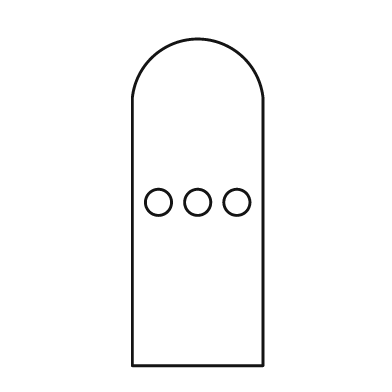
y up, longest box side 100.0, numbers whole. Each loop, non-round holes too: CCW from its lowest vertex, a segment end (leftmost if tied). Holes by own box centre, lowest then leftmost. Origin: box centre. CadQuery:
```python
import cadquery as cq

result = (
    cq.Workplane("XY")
    .moveTo(-20.0, -50.0)
    .lineTo(20.0, -50.0)
    .lineTo(20.0, 32.0)
    .threePointArc((0.0, 50.0), (-20.0, 32.0))
    .close()
    .moveTo(-12.0, 0.0)
    .circle(4.0)
    .moveTo(0.0, 0.0)
    .circle(4.0)
    .moveTo(12.0, 0.0)
    .circle(4.0)
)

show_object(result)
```